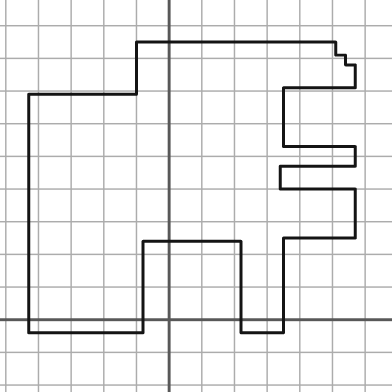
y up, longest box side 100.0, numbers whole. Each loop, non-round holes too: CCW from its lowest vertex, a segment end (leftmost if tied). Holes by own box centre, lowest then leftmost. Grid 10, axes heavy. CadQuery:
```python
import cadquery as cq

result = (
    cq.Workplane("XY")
    .moveTo(-43.0, -4.0)
    .lineTo(-8.0, -4.0)
    .lineTo(-8.0, 24.0)
    .lineTo(22.0, 24.0)
    .lineTo(22.0, -4.0)
    .lineTo(35.0, -4.0)
    .lineTo(35.0, 25.0)
    .lineTo(57.0, 25.0)
    .lineTo(57.0, 40.0)
    .lineTo(34.0, 40.0)
    .lineTo(34.0, 47.0)
    .lineTo(57.0, 47.0)
    .lineTo(57.0, 53.0)
    .lineTo(35.0, 53.0)
    .lineTo(35.0, 71.0)
    .lineTo(57.0, 71.0)
    .lineTo(57.0, 78.0)
    .lineTo(54.0, 78.0)
    .lineTo(54.0, 81.0)
    .lineTo(51.0, 81.0)
    .lineTo(51.0, 85.0)
    .lineTo(-10.0, 85.0)
    .lineTo(-10.0, 69.0)
    .lineTo(-43.0, 69.0)
    .close()
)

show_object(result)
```